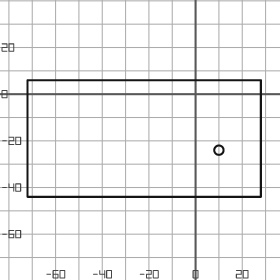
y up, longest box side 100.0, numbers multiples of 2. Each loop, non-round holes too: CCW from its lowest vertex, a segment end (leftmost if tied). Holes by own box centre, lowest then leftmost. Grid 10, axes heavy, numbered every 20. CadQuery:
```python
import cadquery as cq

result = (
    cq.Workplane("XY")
    .moveTo(-72.0, -44.0)
    .lineTo(28.0, -44.0)
    .lineTo(28.0, 6.0)
    .lineTo(-72.0, 6.0)
    .close()
    .moveTo(10.0, -24.0)
    .circle(2.0)
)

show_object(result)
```